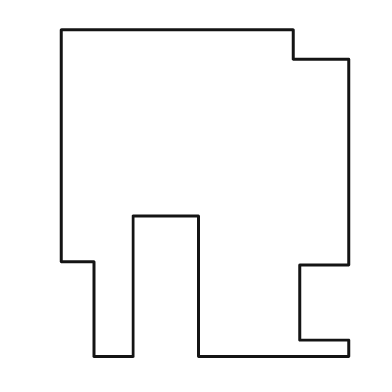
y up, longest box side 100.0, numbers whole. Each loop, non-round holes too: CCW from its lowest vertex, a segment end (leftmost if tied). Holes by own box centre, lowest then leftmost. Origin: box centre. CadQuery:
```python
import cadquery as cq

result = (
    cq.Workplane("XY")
    .moveTo(-34.0, -50.0)
    .lineTo(-22.0, -50.0)
    .lineTo(-22.0, -7.0)
    .lineTo(-2.0, -7.0)
    .lineTo(-2.0, -50.0)
    .lineTo(44.0, -50.0)
    .lineTo(44.0, -45.0)
    .lineTo(29.0, -45.0)
    .lineTo(29.0, -22.0)
    .lineTo(44.0, -22.0)
    .lineTo(44.0, 41.0)
    .lineTo(27.0, 41.0)
    .lineTo(27.0, 50.0)
    .lineTo(-44.0, 50.0)
    .lineTo(-44.0, -21.0)
    .lineTo(-34.0, -21.0)
    .close()
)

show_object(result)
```